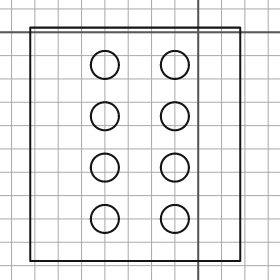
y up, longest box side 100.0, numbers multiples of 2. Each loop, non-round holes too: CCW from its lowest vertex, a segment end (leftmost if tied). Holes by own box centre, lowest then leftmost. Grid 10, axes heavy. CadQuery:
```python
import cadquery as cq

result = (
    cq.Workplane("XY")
    .moveTo(-72.0, -98.0)
    .lineTo(18.0, -98.0)
    .lineTo(18.0, 2.0)
    .lineTo(-72.0, 2.0)
    .close()
    .moveTo(-40.0, -80.0)
    .circle(6.0)
    .moveTo(-10.0, -80.0)
    .circle(6.0)
    .moveTo(-40.0, -58.0)
    .circle(6.0)
    .moveTo(-10.0, -58.0)
    .circle(6.0)
    .moveTo(-40.0, -36.0)
    .circle(6.0)
    .moveTo(-10.0, -36.0)
    .circle(6.0)
    .moveTo(-40.0, -14.0)
    .circle(6.0)
    .moveTo(-10.0, -14.0)
    .circle(6.0)
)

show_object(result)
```